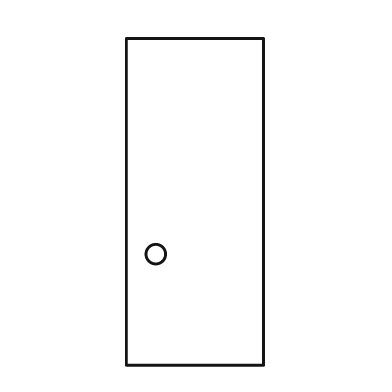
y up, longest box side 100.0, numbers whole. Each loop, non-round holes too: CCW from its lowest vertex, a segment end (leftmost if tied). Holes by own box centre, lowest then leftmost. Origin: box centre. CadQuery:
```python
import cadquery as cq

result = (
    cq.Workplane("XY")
    .moveTo(-21.0, -50.0)
    .lineTo(21.0, -50.0)
    .lineTo(21.0, 50.0)
    .lineTo(-21.0, 50.0)
    .close()
    .moveTo(-12.0, -16.0)
    .circle(3.0)
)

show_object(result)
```